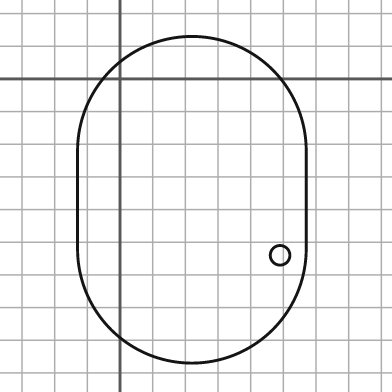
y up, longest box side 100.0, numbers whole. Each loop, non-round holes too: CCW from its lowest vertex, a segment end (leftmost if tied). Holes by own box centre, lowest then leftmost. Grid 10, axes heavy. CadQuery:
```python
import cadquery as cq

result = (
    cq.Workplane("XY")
    .moveTo(-13.0, -52.0)
    .threePointArc((22.0, -87.0), (57.0, -52.0))
    .lineTo(57.0, -22.0)
    .threePointArc((22.0, 13.0), (-13.0, -22.0))
    .close()
    .moveTo(49.0, -54.0)
    .circle(3.0)
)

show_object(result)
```